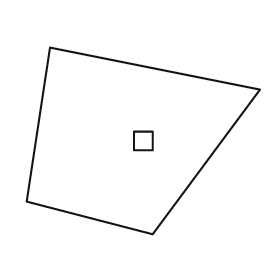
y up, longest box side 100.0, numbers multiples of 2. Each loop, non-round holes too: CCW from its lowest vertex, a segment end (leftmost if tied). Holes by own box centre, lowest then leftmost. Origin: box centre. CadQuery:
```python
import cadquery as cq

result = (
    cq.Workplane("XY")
    .moveTo(4.0, -40.0)
    .lineTo(50.0, 22.0)
    .lineTo(-40.0, 40.0)
    .lineTo(-50.0, -26.0)
    .close()
    .moveTo(-4.0, -4.0)
    .lineTo(4.0, -4.0)
    .lineTo(4.0, 4.0)
    .lineTo(-4.0, 4.0)
    .close()
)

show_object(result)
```